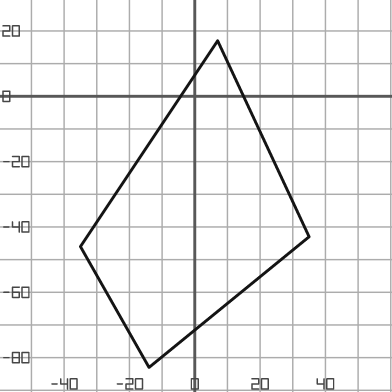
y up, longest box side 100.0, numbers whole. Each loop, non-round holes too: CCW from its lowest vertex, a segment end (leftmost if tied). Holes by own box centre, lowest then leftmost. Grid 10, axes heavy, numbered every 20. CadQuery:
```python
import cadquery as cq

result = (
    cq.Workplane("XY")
    .moveTo(-14.0, -83.0)
    .lineTo(35.0, -43.0)
    .lineTo(7.0, 17.0)
    .lineTo(-35.0, -46.0)
    .close()
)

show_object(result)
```